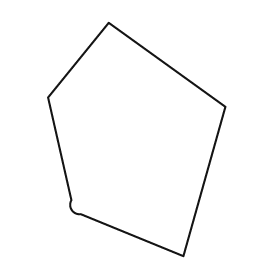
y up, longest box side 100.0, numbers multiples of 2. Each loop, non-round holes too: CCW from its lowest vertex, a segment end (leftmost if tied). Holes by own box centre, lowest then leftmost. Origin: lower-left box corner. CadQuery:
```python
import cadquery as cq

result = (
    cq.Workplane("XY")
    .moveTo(58.0, 0.0)
    .lineTo(76.0, 64.0)
    .lineTo(26.0, 100.0)
    .lineTo(0.0, 68.0)
    .lineTo(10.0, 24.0)
    .threePointArc((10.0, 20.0), (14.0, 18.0))
    .close()
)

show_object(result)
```